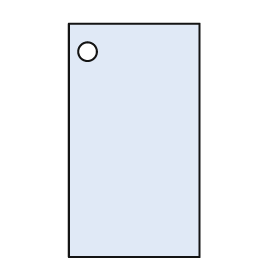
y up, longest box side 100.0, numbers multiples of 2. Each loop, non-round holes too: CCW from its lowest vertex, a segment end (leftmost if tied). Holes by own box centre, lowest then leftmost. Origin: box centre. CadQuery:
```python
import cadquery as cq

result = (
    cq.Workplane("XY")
    .moveTo(-28.0, -50.0)
    .lineTo(28.0, -50.0)
    .lineTo(28.0, 50.0)
    .lineTo(-28.0, 50.0)
    .close()
    .moveTo(-20.0, 38.0)
    .circle(4.0)
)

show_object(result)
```